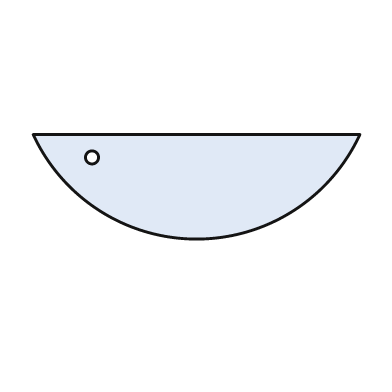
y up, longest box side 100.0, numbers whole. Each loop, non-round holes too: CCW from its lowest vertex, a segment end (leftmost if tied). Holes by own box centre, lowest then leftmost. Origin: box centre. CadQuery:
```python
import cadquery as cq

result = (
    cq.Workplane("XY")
    .moveTo(-50.0, 16.0)
    .threePointArc((0.0, -16.0), (50.0, 16.0))
    .close()
    .moveTo(-32.0, 9.0)
    .circle(2.0)
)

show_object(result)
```